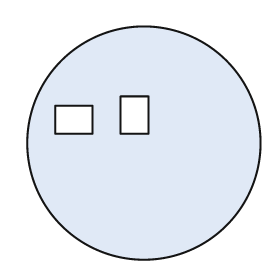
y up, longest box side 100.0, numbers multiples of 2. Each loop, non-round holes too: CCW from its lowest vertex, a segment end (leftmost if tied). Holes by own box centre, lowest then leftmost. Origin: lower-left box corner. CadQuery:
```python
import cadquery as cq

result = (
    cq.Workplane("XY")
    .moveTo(50.0, 50.0)
    .circle(50.0)
    .moveTo(12.0, 54.0)
    .lineTo(28.0, 54.0)
    .lineTo(28.0, 66.0)
    .lineTo(12.0, 66.0)
    .close()
    .moveTo(40.0, 54.0)
    .lineTo(52.0, 54.0)
    .lineTo(52.0, 70.0)
    .lineTo(40.0, 70.0)
    .close()
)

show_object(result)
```